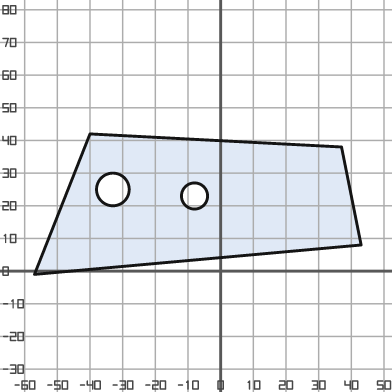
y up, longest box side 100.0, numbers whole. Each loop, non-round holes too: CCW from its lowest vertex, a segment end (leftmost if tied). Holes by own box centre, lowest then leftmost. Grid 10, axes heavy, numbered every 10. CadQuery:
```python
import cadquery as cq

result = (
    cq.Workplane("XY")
    .moveTo(-57.0, -1.0)
    .lineTo(43.0, 8.0)
    .lineTo(37.0, 38.0)
    .lineTo(-40.0, 42.0)
    .close()
    .moveTo(-8.0, 23.0)
    .circle(4.0)
    .moveTo(-33.0, 25.0)
    .circle(5.0)
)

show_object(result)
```